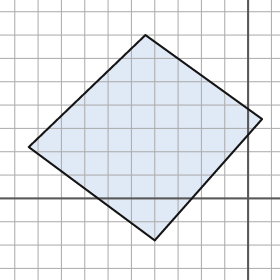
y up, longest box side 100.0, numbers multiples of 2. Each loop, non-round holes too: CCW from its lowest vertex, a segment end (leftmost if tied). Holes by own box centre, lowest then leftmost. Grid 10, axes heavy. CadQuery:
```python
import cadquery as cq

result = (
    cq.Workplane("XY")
    .moveTo(-40.0, -18.0)
    .lineTo(6.0, 34.0)
    .lineTo(-44.0, 70.0)
    .lineTo(-94.0, 22.0)
    .close()
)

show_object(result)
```